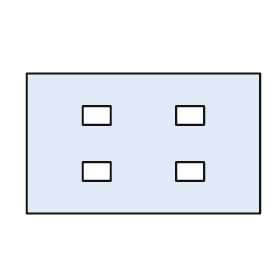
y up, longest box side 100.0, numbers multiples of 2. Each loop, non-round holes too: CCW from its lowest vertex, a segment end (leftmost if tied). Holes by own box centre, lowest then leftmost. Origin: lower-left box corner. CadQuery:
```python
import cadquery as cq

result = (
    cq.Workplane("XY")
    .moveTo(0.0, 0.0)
    .lineTo(100.0, 0.0)
    .lineTo(100.0, 60.0)
    .lineTo(0.0, 60.0)
    .close()
    .moveTo(24.0, 14.0)
    .lineTo(36.0, 14.0)
    .lineTo(36.0, 22.0)
    .lineTo(24.0, 22.0)
    .close()
    .moveTo(64.0, 14.0)
    .lineTo(76.0, 14.0)
    .lineTo(76.0, 22.0)
    .lineTo(64.0, 22.0)
    .close()
    .moveTo(24.0, 38.0)
    .lineTo(36.0, 38.0)
    .lineTo(36.0, 46.0)
    .lineTo(24.0, 46.0)
    .close()
    .moveTo(64.0, 38.0)
    .lineTo(76.0, 38.0)
    .lineTo(76.0, 46.0)
    .lineTo(64.0, 46.0)
    .close()
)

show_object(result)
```